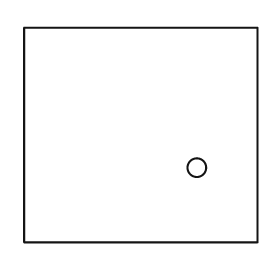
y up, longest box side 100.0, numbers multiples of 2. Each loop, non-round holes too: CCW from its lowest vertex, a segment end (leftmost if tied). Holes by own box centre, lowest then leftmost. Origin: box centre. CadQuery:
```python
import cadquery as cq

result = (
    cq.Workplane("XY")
    .moveTo(-50.0, -46.0)
    .lineTo(50.0, -46.0)
    .lineTo(50.0, 46.0)
    .lineTo(-50.0, 46.0)
    .close()
    .moveTo(24.0, -14.0)
    .circle(4.0)
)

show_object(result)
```